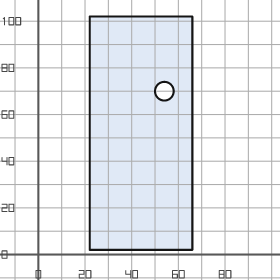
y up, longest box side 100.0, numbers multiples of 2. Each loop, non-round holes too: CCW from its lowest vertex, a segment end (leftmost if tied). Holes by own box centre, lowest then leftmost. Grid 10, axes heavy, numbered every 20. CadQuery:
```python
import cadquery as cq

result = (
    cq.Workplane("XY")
    .moveTo(22.0, 2.0)
    .lineTo(66.0, 2.0)
    .lineTo(66.0, 102.0)
    .lineTo(22.0, 102.0)
    .close()
    .moveTo(54.0, 70.0)
    .circle(4.0)
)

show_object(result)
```